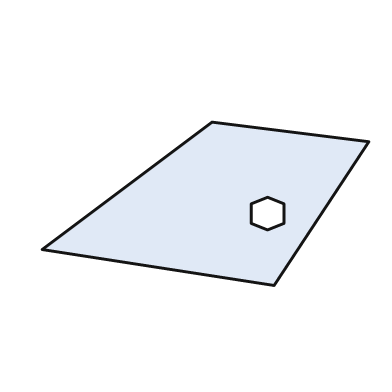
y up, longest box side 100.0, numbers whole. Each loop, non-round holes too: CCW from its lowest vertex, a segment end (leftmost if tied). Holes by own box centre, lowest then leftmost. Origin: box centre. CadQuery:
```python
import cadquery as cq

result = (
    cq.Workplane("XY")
    .moveTo(21.0, -25.0)
    .lineTo(50.0, 19.0)
    .lineTo(2.0, 25.0)
    .lineTo(-50.0, -14.0)
    .close()
    .moveTo(19.0, -8.0)
    .lineTo(24.0, -6.0)
    .lineTo(24.0, 0.0)
    .lineTo(19.0, 2.0)
    .lineTo(14.0, 0.0)
    .lineTo(14.0, -6.0)
    .close()
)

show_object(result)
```